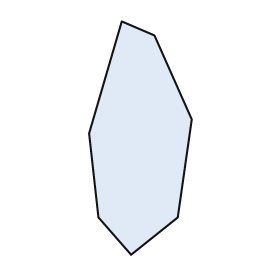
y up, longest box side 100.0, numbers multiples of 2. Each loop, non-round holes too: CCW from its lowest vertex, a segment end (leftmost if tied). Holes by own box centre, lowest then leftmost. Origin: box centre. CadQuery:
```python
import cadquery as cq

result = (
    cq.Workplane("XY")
    .moveTo(-4.0, -50.0)
    .lineTo(16.0, -34.0)
    .lineTo(22.0, 8.0)
    .lineTo(6.0, 44.0)
    .lineTo(-8.0, 50.0)
    .lineTo(-22.0, 2.0)
    .lineTo(-18.0, -34.0)
    .close()
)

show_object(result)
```